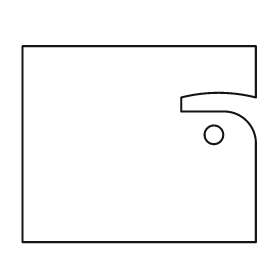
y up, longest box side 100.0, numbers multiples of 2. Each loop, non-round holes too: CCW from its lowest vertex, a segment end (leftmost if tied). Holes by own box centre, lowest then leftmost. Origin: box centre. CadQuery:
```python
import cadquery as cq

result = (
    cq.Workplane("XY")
    .moveTo(-50.0, -42.0)
    .lineTo(50.0, -42.0)
    .lineTo(50.0, 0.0)
    .threePointArc((46.0, 10.0), (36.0, 14.0))
    .lineTo(18.0, 14.0)
    .lineTo(18.0, 20.0)
    .threePointArc((34.0, 22.0), (50.0, 20.0))
    .lineTo(50.0, 42.0)
    .lineTo(-50.0, 42.0)
    .close()
    .moveTo(32.0, 4.0)
    .circle(4.0)
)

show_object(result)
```